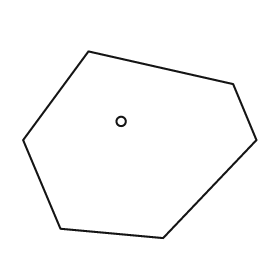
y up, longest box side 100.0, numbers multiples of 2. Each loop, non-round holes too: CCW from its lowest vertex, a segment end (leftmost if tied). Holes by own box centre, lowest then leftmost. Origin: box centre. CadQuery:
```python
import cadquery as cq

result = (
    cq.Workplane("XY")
    .moveTo(10.0, -40.0)
    .lineTo(50.0, 2.0)
    .lineTo(40.0, 26.0)
    .lineTo(-22.0, 40.0)
    .lineTo(-50.0, 2.0)
    .lineTo(-34.0, -36.0)
    .close()
    .moveTo(-8.0, 10.0)
    .circle(2.0)
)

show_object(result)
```